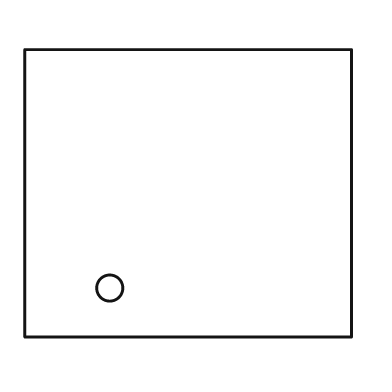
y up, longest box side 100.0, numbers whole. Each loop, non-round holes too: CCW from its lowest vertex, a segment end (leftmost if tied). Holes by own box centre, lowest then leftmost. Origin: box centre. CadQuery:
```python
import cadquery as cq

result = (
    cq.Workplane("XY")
    .moveTo(-50.0, -44.0)
    .lineTo(50.0, -44.0)
    .lineTo(50.0, 44.0)
    .lineTo(-50.0, 44.0)
    .close()
    .moveTo(-24.0, -29.0)
    .circle(4.0)
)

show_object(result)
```